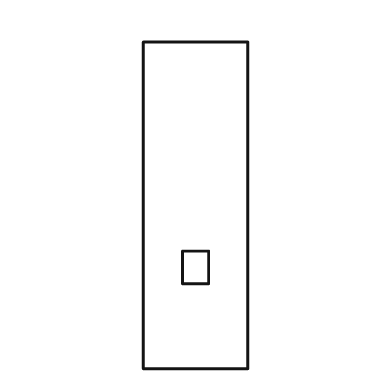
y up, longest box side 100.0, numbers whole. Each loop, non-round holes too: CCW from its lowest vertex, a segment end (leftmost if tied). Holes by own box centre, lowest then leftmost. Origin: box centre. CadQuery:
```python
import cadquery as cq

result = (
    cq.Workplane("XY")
    .moveTo(-16.0, -50.0)
    .lineTo(16.0, -50.0)
    .lineTo(16.0, 50.0)
    .lineTo(-16.0, 50.0)
    .close()
    .moveTo(-4.0, -24.0)
    .lineTo(4.0, -24.0)
    .lineTo(4.0, -14.0)
    .lineTo(-4.0, -14.0)
    .close()
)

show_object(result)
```